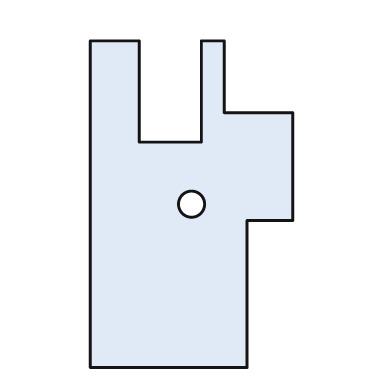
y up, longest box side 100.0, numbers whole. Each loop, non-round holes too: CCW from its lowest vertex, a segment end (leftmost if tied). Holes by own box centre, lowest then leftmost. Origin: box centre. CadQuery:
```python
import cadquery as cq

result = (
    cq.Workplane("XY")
    .moveTo(-31.0, -50.0)
    .lineTo(17.0, -50.0)
    .lineTo(17.0, -5.0)
    .lineTo(31.0, -5.0)
    .lineTo(31.0, 28.0)
    .lineTo(10.0, 28.0)
    .lineTo(10.0, 50.0)
    .lineTo(3.0, 50.0)
    .lineTo(3.0, 19.0)
    .lineTo(-16.0, 19.0)
    .lineTo(-16.0, 50.0)
    .lineTo(-31.0, 50.0)
    .close()
    .moveTo(0.0, 0.0)
    .circle(4.0)
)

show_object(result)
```